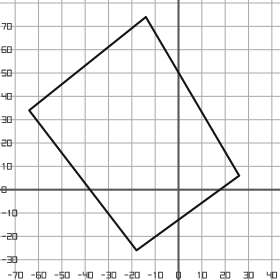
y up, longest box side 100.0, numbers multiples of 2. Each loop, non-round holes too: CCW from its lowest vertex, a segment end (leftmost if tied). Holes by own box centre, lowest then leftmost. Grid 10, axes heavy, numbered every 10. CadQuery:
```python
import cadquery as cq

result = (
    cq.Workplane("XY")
    .moveTo(-18.0, -26.0)
    .lineTo(26.0, 6.0)
    .lineTo(-14.0, 74.0)
    .lineTo(-64.0, 34.0)
    .close()
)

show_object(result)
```